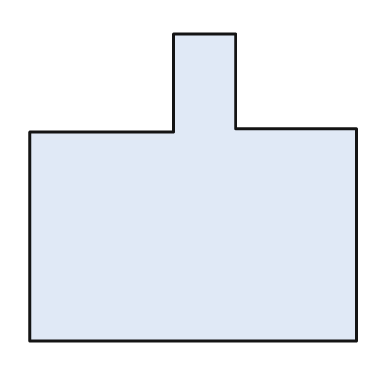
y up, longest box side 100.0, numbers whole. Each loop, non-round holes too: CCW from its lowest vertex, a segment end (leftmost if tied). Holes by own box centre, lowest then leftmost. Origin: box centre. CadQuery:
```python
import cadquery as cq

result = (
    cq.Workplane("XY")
    .moveTo(-50.0, -47.0)
    .lineTo(50.0, -47.0)
    .lineTo(50.0, 18.0)
    .lineTo(13.0, 18.0)
    .lineTo(13.0, 47.0)
    .lineTo(-6.0, 47.0)
    .lineTo(-6.0, 17.0)
    .lineTo(-50.0, 17.0)
    .close()
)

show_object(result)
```